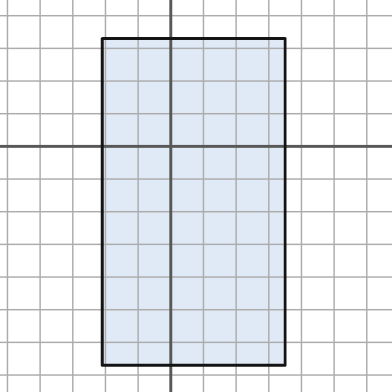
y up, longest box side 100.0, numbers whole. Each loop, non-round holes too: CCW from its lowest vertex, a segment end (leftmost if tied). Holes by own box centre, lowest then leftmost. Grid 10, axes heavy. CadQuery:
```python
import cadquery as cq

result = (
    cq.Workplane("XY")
    .moveTo(-21.0, -67.0)
    .lineTo(35.0, -67.0)
    .lineTo(35.0, 33.0)
    .lineTo(-21.0, 33.0)
    .close()
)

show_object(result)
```